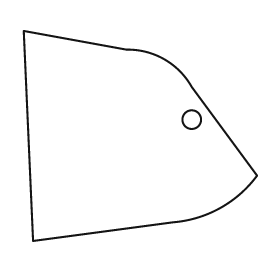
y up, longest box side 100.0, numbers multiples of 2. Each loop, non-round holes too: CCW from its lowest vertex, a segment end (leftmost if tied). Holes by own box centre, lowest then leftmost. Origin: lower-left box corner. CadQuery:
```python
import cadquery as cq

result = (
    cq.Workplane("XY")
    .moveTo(4.0, 0.0)
    .lineTo(64.0, 8.0)
    .threePointArc((84.0, 14.0), (100.0, 28.0))
    .lineTo(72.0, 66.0)
    .threePointArc((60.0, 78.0), (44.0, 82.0))
    .lineTo(0.0, 90.0)
    .close()
    .moveTo(72.0, 52.0)
    .circle(4.0)
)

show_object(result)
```